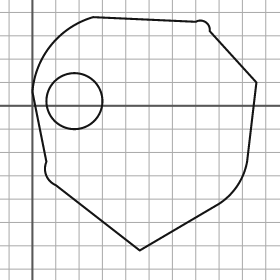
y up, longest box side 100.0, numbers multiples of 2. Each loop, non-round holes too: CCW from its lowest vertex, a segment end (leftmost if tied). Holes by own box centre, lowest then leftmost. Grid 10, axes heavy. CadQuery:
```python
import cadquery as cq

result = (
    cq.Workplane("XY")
    .moveTo(46.0, -62.0)
    .lineTo(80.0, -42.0)
    .threePointArc((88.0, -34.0), (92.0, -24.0))
    .lineTo(96.0, 10.0)
    .lineTo(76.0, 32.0)
    .threePointArc((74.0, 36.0), (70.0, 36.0))
    .lineTo(26.0, 38.0)
    .threePointArc((8.0, 26.0), (0.0, 6.0))
    .lineTo(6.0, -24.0)
    .threePointArc((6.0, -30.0), (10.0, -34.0))
    .close()
    .moveTo(18.0, 2.0)
    .circle(12.0)
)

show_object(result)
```